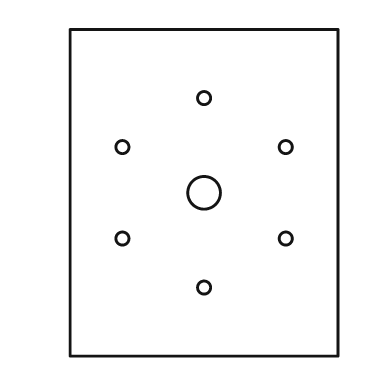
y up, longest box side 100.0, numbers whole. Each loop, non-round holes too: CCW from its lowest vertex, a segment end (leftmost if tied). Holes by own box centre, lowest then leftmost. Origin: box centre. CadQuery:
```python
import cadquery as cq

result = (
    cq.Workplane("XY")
    .moveTo(-41.0, -50.0)
    .lineTo(41.0, -50.0)
    .lineTo(41.0, 50.0)
    .lineTo(-41.0, 50.0)
    .close()
    .moveTo(0.0, -29.0)
    .circle(2.0)
    .moveTo(-25.0, -14.0)
    .circle(2.0)
    .moveTo(25.0, -14.0)
    .circle(2.0)
    .moveTo(0.0, 0.0)
    .circle(5.0)
    .moveTo(-25.0, 14.0)
    .circle(2.0)
    .moveTo(25.0, 14.0)
    .circle(2.0)
    .moveTo(0.0, 29.0)
    .circle(2.0)
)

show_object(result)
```